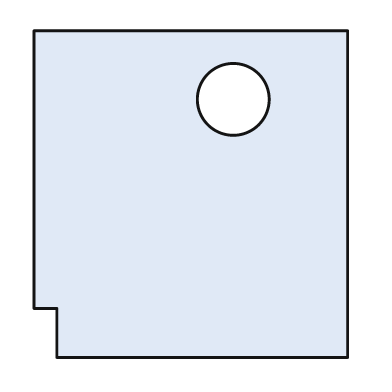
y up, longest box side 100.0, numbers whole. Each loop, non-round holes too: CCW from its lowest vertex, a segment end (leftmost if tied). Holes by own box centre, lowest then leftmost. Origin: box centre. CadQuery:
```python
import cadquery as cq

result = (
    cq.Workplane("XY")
    .moveTo(-41.0, -50.0)
    .lineTo(48.0, -50.0)
    .lineTo(48.0, 50.0)
    .lineTo(-48.0, 50.0)
    .lineTo(-48.0, -35.0)
    .lineTo(-41.0, -35.0)
    .close()
    .moveTo(13.0, 29.0)
    .circle(11.0)
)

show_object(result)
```